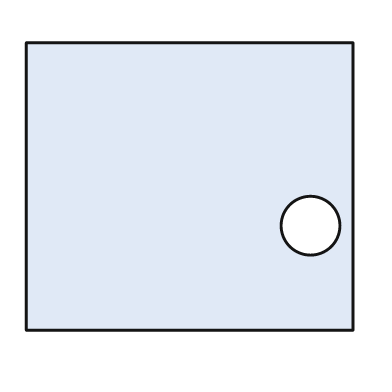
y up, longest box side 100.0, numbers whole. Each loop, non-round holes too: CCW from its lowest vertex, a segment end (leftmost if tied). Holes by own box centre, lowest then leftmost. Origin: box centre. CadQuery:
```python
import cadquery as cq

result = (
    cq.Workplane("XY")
    .moveTo(-50.0, -44.0)
    .lineTo(50.0, -44.0)
    .lineTo(50.0, 44.0)
    .lineTo(-50.0, 44.0)
    .close()
    .moveTo(37.0, -12.0)
    .circle(9.0)
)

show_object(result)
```